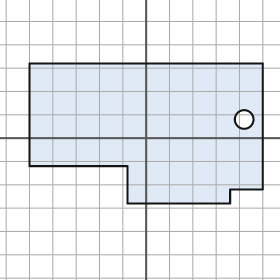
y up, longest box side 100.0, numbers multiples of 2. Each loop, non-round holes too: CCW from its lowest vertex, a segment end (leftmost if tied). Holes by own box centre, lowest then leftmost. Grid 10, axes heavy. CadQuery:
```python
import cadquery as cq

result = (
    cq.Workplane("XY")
    .moveTo(-8.0, -28.0)
    .lineTo(36.0, -28.0)
    .lineTo(36.0, -22.0)
    .lineTo(50.0, -22.0)
    .lineTo(50.0, 32.0)
    .lineTo(-50.0, 32.0)
    .lineTo(-50.0, -12.0)
    .lineTo(-8.0, -12.0)
    .close()
    .moveTo(42.0, 8.0)
    .circle(4.0)
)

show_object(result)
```